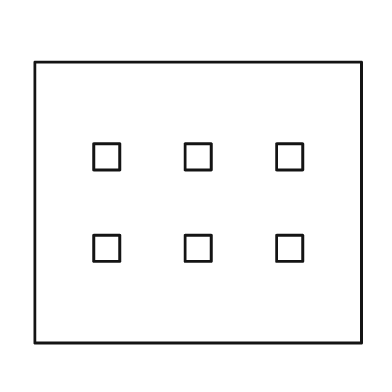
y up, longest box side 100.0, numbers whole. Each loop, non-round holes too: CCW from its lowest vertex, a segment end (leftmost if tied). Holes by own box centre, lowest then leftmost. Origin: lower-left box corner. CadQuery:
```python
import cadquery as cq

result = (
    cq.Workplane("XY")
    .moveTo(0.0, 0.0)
    .lineTo(100.0, 0.0)
    .lineTo(100.0, 86.0)
    .lineTo(0.0, 86.0)
    .close()
    .moveTo(18.0, 25.0)
    .lineTo(26.0, 25.0)
    .lineTo(26.0, 33.0)
    .lineTo(18.0, 33.0)
    .close()
    .moveTo(46.0, 25.0)
    .lineTo(54.0, 25.0)
    .lineTo(54.0, 33.0)
    .lineTo(46.0, 33.0)
    .close()
    .moveTo(74.0, 25.0)
    .lineTo(82.0, 25.0)
    .lineTo(82.0, 33.0)
    .lineTo(74.0, 33.0)
    .close()
    .moveTo(18.0, 53.0)
    .lineTo(26.0, 53.0)
    .lineTo(26.0, 61.0)
    .lineTo(18.0, 61.0)
    .close()
    .moveTo(46.0, 53.0)
    .lineTo(54.0, 53.0)
    .lineTo(54.0, 61.0)
    .lineTo(46.0, 61.0)
    .close()
    .moveTo(74.0, 53.0)
    .lineTo(82.0, 53.0)
    .lineTo(82.0, 61.0)
    .lineTo(74.0, 61.0)
    .close()
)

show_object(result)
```